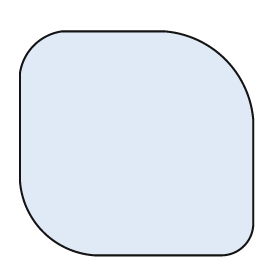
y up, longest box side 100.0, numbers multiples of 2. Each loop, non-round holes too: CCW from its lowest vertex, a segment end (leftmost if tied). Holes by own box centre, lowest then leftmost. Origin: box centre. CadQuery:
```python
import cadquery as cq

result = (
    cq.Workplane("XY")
    .moveTo(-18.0, -48.0)
    .lineTo(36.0, -48.0)
    .threePointArc((46.0, -44.0), (50.0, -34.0))
    .lineTo(50.0, 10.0)
    .threePointArc((38.0, 36.0), (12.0, 48.0))
    .lineTo(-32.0, 48.0)
    .threePointArc((-44.0, 42.0), (-50.0, 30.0))
    .lineTo(-50.0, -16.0)
    .threePointArc((-40.0, -38.0), (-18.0, -48.0))
    .close()
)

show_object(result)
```